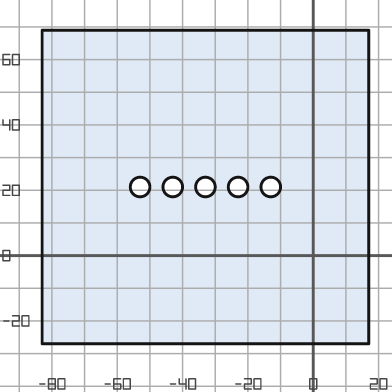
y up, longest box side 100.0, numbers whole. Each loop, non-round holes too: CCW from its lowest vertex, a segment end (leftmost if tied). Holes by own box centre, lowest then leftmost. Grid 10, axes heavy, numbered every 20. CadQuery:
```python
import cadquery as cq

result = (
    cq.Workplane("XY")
    .moveTo(-83.0, -27.0)
    .lineTo(17.0, -27.0)
    .lineTo(17.0, 69.0)
    .lineTo(-83.0, 69.0)
    .close()
    .moveTo(-53.0, 21.0)
    .circle(3.0)
    .moveTo(-43.0, 21.0)
    .circle(3.0)
    .moveTo(-33.0, 21.0)
    .circle(3.0)
    .moveTo(-23.0, 21.0)
    .circle(3.0)
    .moveTo(-13.0, 21.0)
    .circle(3.0)
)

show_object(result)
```